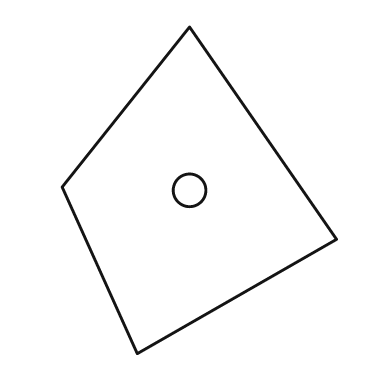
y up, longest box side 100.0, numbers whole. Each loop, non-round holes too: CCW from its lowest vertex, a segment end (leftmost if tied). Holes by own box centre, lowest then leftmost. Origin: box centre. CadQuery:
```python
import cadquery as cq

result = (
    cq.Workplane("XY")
    .moveTo(-19.0, -50.0)
    .lineTo(42.0, -15.0)
    .lineTo(-3.0, 50.0)
    .lineTo(-42.0, 1.0)
    .close()
    .moveTo(-3.0, 0.0)
    .circle(5.0)
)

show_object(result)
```